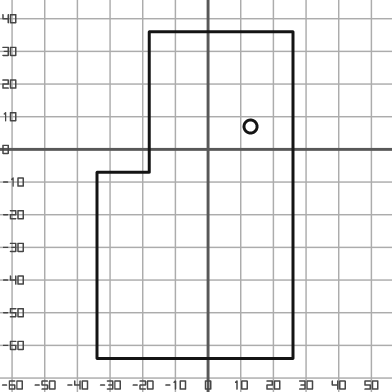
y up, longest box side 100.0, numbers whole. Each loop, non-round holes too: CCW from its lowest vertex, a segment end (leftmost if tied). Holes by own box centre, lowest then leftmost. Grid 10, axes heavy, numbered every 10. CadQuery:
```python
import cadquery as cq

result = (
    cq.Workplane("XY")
    .moveTo(-34.0, -64.0)
    .lineTo(26.0, -64.0)
    .lineTo(26.0, 36.0)
    .lineTo(-18.0, 36.0)
    .lineTo(-18.0, -7.0)
    .lineTo(-34.0, -7.0)
    .close()
    .moveTo(13.0, 7.0)
    .circle(2.0)
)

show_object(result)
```